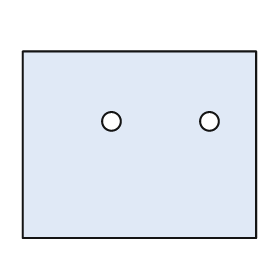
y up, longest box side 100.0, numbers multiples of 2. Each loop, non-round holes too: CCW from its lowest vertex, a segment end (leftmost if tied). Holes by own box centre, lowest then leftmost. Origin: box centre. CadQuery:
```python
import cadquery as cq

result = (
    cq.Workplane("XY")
    .moveTo(-50.0, -40.0)
    .lineTo(50.0, -40.0)
    .lineTo(50.0, 40.0)
    .lineTo(-50.0, 40.0)
    .close()
    .moveTo(-12.0, 10.0)
    .circle(4.0)
    .moveTo(30.0, 10.0)
    .circle(4.0)
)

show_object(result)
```